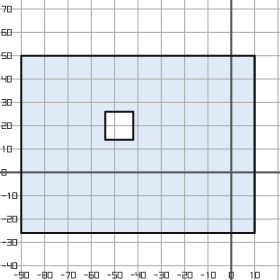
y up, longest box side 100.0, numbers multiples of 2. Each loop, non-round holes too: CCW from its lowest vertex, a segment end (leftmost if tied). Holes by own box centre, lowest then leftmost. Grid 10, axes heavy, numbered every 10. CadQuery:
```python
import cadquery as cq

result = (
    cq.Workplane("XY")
    .moveTo(-90.0, -26.0)
    .lineTo(10.0, -26.0)
    .lineTo(10.0, 50.0)
    .lineTo(-90.0, 50.0)
    .close()
    .moveTo(-54.0, 14.0)
    .lineTo(-42.0, 14.0)
    .lineTo(-42.0, 26.0)
    .lineTo(-54.0, 26.0)
    .close()
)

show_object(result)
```